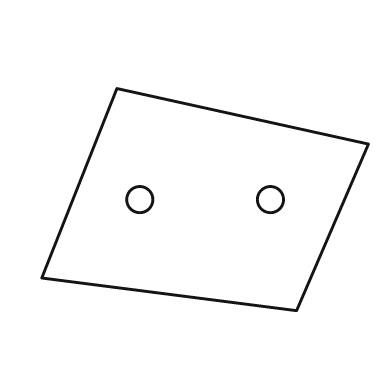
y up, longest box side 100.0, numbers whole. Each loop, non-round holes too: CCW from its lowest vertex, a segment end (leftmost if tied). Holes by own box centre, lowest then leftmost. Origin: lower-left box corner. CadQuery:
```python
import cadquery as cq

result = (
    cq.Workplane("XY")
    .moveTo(78.0, 0.0)
    .lineTo(100.0, 51.0)
    .lineTo(23.0, 68.0)
    .lineTo(0.0, 10.0)
    .close()
    .moveTo(30.0, 34.0)
    .circle(4.0)
    .moveTo(70.0, 34.0)
    .circle(4.0)
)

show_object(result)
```